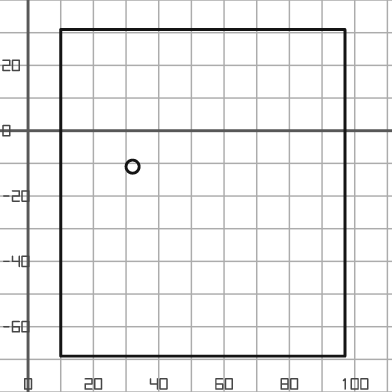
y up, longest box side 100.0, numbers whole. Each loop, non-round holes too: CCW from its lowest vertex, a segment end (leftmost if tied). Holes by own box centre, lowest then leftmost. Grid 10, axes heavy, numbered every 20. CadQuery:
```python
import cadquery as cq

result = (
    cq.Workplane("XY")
    .moveTo(10.0, -69.0)
    .lineTo(97.0, -69.0)
    .lineTo(97.0, 31.0)
    .lineTo(10.0, 31.0)
    .close()
    .moveTo(32.0, -11.0)
    .circle(2.0)
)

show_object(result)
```